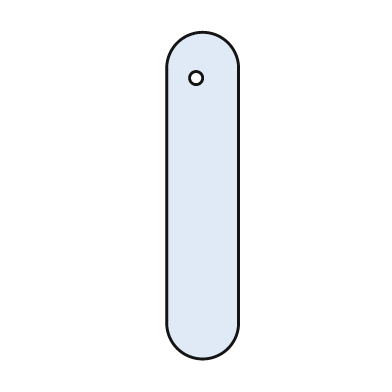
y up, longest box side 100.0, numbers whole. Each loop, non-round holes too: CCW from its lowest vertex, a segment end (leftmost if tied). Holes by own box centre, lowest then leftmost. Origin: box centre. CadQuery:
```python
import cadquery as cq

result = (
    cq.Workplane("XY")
    .moveTo(-11.0, -39.0)
    .threePointArc((0.0, -50.0), (11.0, -39.0))
    .lineTo(11.0, 39.0)
    .threePointArc((0.0, 50.0), (-11.0, 39.0))
    .close()
    .moveTo(-2.0, 36.0)
    .circle(2.0)
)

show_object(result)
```